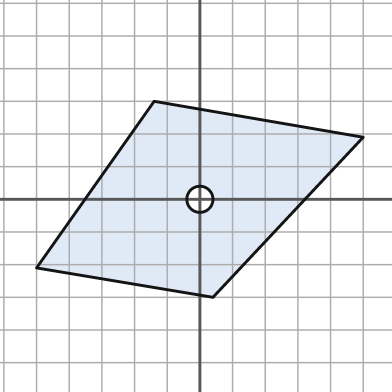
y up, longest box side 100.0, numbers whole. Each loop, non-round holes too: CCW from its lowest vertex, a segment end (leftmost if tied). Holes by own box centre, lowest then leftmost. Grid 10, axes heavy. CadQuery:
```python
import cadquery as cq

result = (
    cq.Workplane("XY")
    .moveTo(4.0, -30.0)
    .lineTo(50.0, 19.0)
    .lineTo(-14.0, 30.0)
    .lineTo(-50.0, -21.0)
    .close()
    .moveTo(0.0, 0.0)
    .circle(4.0)
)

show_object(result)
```